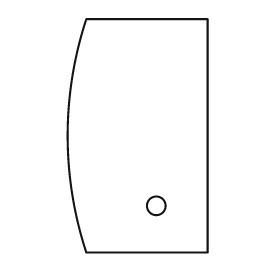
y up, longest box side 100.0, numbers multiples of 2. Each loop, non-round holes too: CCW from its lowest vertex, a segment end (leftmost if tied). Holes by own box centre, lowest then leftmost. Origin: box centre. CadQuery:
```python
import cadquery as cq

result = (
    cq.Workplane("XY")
    .moveTo(-22.0, -50.0)
    .lineTo(30.0, -50.0)
    .lineTo(30.0, 50.0)
    .lineTo(-22.0, 50.0)
    .threePointArc((-30.0, 0.0), (-22.0, -50.0))
    .close()
    .moveTo(8.0, -30.0)
    .circle(4.0)
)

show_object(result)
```